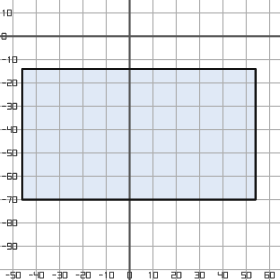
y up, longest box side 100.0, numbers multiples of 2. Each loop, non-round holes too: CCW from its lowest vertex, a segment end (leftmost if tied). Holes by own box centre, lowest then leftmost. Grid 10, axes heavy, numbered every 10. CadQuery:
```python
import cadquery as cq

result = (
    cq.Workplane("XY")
    .moveTo(-46.0, -70.0)
    .lineTo(54.0, -70.0)
    .lineTo(54.0, -14.0)
    .lineTo(-46.0, -14.0)
    .close()
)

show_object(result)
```